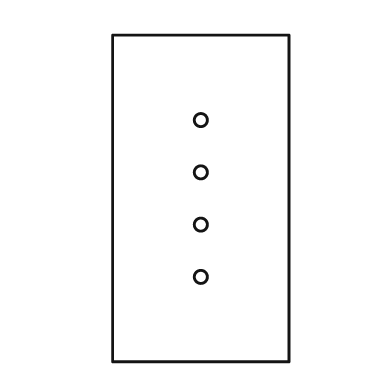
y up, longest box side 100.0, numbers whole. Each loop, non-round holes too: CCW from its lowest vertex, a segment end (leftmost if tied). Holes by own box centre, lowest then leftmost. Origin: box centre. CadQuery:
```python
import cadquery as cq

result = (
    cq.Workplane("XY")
    .moveTo(-27.0, -50.0)
    .lineTo(27.0, -50.0)
    .lineTo(27.0, 50.0)
    .lineTo(-27.0, 50.0)
    .close()
    .moveTo(0.0, -24.0)
    .circle(2.0)
    .moveTo(0.0, -8.0)
    .circle(2.0)
    .moveTo(0.0, 8.0)
    .circle(2.0)
    .moveTo(0.0, 24.0)
    .circle(2.0)
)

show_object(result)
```